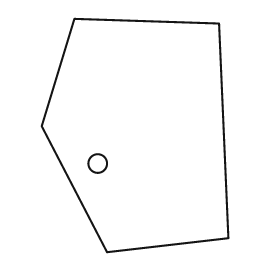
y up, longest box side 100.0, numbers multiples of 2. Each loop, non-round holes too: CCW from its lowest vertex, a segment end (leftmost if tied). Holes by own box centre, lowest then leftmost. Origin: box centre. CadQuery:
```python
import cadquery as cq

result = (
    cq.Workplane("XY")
    .moveTo(-12.0, -50.0)
    .lineTo(40.0, -44.0)
    .lineTo(36.0, 48.0)
    .lineTo(-26.0, 50.0)
    .lineTo(-40.0, 4.0)
    .close()
    .moveTo(-16.0, -12.0)
    .circle(4.0)
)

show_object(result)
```